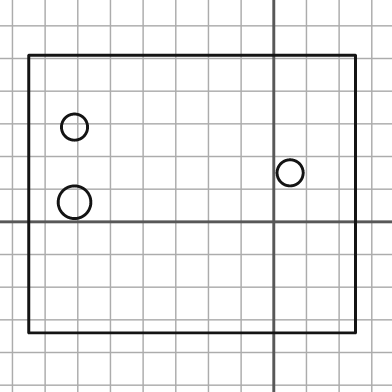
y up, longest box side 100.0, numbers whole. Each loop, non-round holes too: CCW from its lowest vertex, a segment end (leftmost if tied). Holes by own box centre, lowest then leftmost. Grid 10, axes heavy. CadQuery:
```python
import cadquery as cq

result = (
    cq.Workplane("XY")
    .moveTo(-75.0, -34.0)
    .lineTo(25.0, -34.0)
    .lineTo(25.0, 51.0)
    .lineTo(-75.0, 51.0)
    .close()
    .moveTo(-61.0, 6.0)
    .circle(5.0)
    .moveTo(5.0, 15.0)
    .circle(4.0)
    .moveTo(-61.0, 29.0)
    .circle(4.0)
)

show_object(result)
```